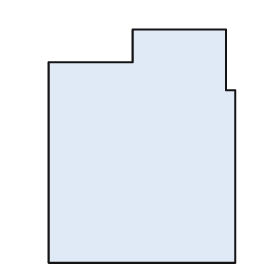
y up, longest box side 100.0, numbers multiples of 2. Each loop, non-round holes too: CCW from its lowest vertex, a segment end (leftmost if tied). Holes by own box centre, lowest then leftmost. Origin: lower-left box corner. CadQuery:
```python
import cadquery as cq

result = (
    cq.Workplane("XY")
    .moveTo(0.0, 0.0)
    .lineTo(80.0, 0.0)
    .lineTo(80.0, 74.0)
    .lineTo(76.0, 74.0)
    .lineTo(76.0, 100.0)
    .lineTo(36.0, 100.0)
    .lineTo(36.0, 86.0)
    .lineTo(0.0, 86.0)
    .close()
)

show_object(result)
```